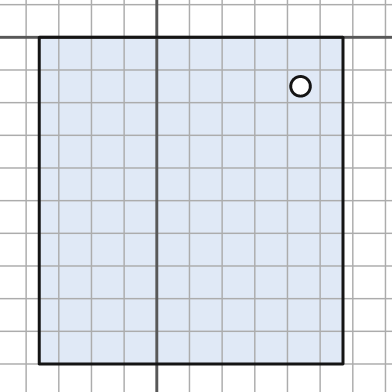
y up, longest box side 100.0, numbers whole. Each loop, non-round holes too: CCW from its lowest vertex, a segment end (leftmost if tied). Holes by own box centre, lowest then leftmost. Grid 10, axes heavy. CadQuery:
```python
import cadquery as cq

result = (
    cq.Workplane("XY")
    .moveTo(-36.0, -100.0)
    .lineTo(57.0, -100.0)
    .lineTo(57.0, 0.0)
    .lineTo(-36.0, 0.0)
    .close()
    .moveTo(44.0, -15.0)
    .circle(3.0)
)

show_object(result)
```